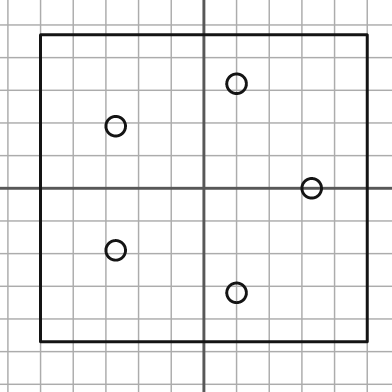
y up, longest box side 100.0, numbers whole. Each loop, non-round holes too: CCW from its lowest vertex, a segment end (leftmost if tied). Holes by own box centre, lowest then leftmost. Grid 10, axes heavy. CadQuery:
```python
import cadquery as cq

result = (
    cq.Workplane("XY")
    .moveTo(-50.0, -47.0)
    .lineTo(50.0, -47.0)
    .lineTo(50.0, 47.0)
    .lineTo(-50.0, 47.0)
    .close()
    .moveTo(10.0, -32.0)
    .circle(3.0)
    .moveTo(-27.0, -19.0)
    .circle(3.0)
    .moveTo(33.0, 0.0)
    .circle(3.0)
    .moveTo(-27.0, 19.0)
    .circle(3.0)
    .moveTo(10.0, 32.0)
    .circle(3.0)
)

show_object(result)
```